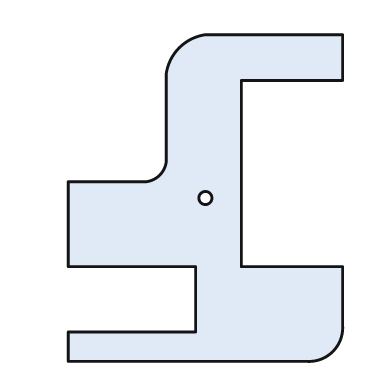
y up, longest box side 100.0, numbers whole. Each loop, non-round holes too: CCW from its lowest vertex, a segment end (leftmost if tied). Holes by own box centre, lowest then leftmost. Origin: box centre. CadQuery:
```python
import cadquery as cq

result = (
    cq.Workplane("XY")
    .moveTo(-42.0, -50.0)
    .lineTo(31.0, -50.0)
    .threePointArc((39.0, -47.0), (42.0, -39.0))
    .lineTo(42.0, -21.0)
    .lineTo(11.0, -21.0)
    .lineTo(11.0, 36.0)
    .lineTo(42.0, 36.0)
    .lineTo(42.0, 50.0)
    .lineTo(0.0, 50.0)
    .threePointArc((-8.0, 46.0), (-12.0, 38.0))
    .lineTo(-12.0, 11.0)
    .threePointArc((-14.0, 7.0), (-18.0, 5.0))
    .lineTo(-42.0, 5.0)
    .lineTo(-42.0, -21.0)
    .lineTo(-3.0, -21.0)
    .lineTo(-3.0, -41.0)
    .lineTo(-42.0, -41.0)
    .close()
    .moveTo(0.0, 0.0)
    .circle(2.0)
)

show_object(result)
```